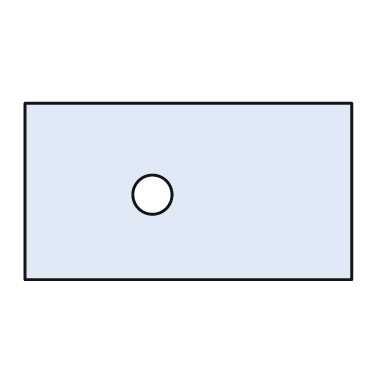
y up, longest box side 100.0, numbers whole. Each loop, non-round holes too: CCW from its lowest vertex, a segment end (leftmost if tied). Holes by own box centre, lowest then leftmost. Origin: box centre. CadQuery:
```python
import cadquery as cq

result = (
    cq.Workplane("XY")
    .moveTo(-50.0, -27.0)
    .lineTo(50.0, -27.0)
    .lineTo(50.0, 27.0)
    .lineTo(-50.0, 27.0)
    .close()
    .moveTo(-11.0, -1.0)
    .circle(6.0)
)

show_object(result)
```